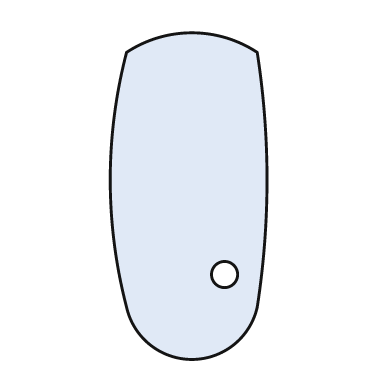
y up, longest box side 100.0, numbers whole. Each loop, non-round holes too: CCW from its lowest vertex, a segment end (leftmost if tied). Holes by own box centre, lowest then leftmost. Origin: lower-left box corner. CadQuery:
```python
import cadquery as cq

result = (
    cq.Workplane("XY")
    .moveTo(5.0, 16.0)
    .threePointArc((25.0, 0.0), (45.0, 16.0))
    .threePointArc((48.0, 55.0), (45.0, 94.0))
    .threePointArc((25.0, 100.0), (5.0, 94.0))
    .threePointArc((0.0, 55.0), (5.0, 16.0))
    .close()
    .moveTo(35.0, 26.0)
    .circle(4.0)
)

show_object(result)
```